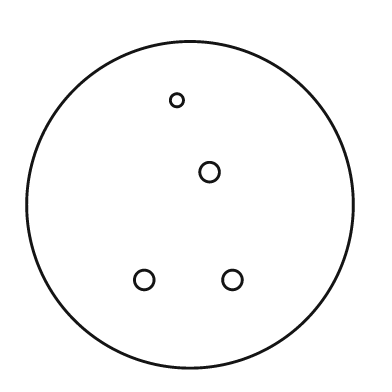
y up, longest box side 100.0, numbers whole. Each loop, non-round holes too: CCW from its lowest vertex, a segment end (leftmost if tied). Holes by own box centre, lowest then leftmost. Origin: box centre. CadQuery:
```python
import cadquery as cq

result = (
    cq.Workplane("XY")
    .moveTo(0.0, 0.0)
    .circle(50.0)
    .moveTo(-14.0, -23.0)
    .circle(3.0)
    .moveTo(13.0, -23.0)
    .circle(3.0)
    .moveTo(6.0, 10.0)
    .circle(3.0)
    .moveTo(-4.0, 32.0)
    .circle(2.0)
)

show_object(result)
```